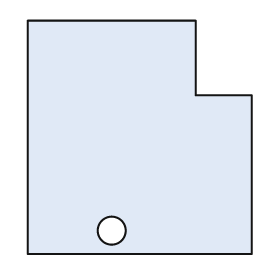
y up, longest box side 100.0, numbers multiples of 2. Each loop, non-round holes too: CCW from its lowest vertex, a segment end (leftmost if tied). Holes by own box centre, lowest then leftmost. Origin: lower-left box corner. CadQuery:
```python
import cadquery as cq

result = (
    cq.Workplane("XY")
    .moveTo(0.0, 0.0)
    .lineTo(96.0, 0.0)
    .lineTo(96.0, 68.0)
    .lineTo(72.0, 68.0)
    .lineTo(72.0, 100.0)
    .lineTo(0.0, 100.0)
    .close()
    .moveTo(36.0, 10.0)
    .circle(6.0)
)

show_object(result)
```